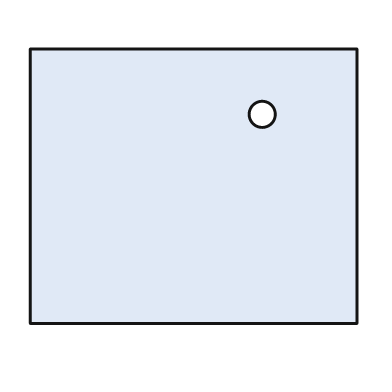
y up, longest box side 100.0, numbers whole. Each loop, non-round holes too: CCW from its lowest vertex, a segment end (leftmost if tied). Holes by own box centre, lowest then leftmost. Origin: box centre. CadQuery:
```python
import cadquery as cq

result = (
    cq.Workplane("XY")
    .moveTo(-50.0, -42.0)
    .lineTo(50.0, -42.0)
    .lineTo(50.0, 42.0)
    .lineTo(-50.0, 42.0)
    .close()
    .moveTo(21.0, 22.0)
    .circle(4.0)
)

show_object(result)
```